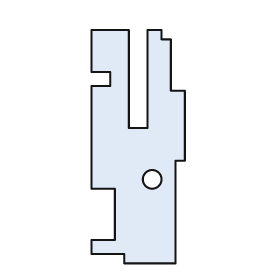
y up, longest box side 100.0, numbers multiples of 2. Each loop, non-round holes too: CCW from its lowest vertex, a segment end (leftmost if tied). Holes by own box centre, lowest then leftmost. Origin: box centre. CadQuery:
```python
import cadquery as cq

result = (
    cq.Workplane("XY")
    .moveTo(-6.0, -50.0)
    .lineTo(16.0, -50.0)
    .lineTo(16.0, -6.0)
    .lineTo(20.0, -6.0)
    .lineTo(20.0, 24.0)
    .lineTo(14.0, 24.0)
    .lineTo(14.0, 46.0)
    .lineTo(10.0, 46.0)
    .lineTo(10.0, 50.0)
    .lineTo(4.0, 50.0)
    .lineTo(4.0, 8.0)
    .lineTo(-4.0, 8.0)
    .lineTo(-4.0, 50.0)
    .lineTo(-20.0, 50.0)
    .lineTo(-20.0, 32.0)
    .lineTo(-12.0, 32.0)
    .lineTo(-12.0, 26.0)
    .lineTo(-20.0, 26.0)
    .lineTo(-20.0, -18.0)
    .lineTo(-10.0, -18.0)
    .lineTo(-10.0, -40.0)
    .lineTo(-20.0, -40.0)
    .lineTo(-20.0, -46.0)
    .lineTo(-6.0, -46.0)
    .close()
    .moveTo(6.0, -14.0)
    .circle(4.0)
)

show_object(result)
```